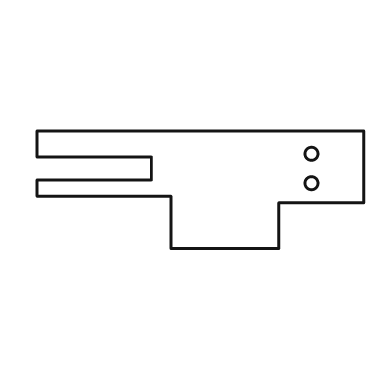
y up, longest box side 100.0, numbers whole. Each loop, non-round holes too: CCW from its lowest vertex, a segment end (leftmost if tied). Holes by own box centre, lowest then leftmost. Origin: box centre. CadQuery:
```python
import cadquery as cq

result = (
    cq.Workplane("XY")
    .moveTo(-9.0, -18.0)
    .lineTo(24.0, -18.0)
    .lineTo(24.0, -4.0)
    .lineTo(50.0, -4.0)
    .lineTo(50.0, 18.0)
    .lineTo(-50.0, 18.0)
    .lineTo(-50.0, 10.0)
    .lineTo(-15.0, 10.0)
    .lineTo(-15.0, 3.0)
    .lineTo(-50.0, 3.0)
    .lineTo(-50.0, -2.0)
    .lineTo(-9.0, -2.0)
    .close()
    .moveTo(34.0, 2.0)
    .circle(2.0)
    .moveTo(34.0, 11.0)
    .circle(2.0)
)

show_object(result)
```